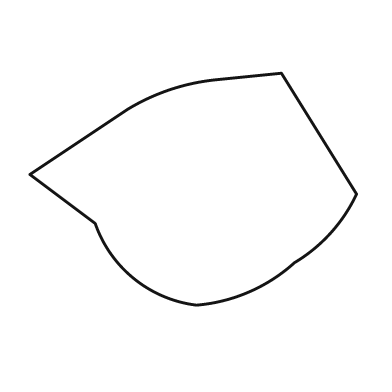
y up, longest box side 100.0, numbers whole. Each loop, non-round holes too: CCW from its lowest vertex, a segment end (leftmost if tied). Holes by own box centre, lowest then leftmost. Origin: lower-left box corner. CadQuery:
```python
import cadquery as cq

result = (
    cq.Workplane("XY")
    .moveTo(51.0, 0.0)
    .threePointArc((67.0, 4.0), (81.0, 13.0))
    .threePointArc((92.0, 22.0), (100.0, 34.0))
    .lineTo(77.0, 71.0)
    .lineTo(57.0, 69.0)
    .threePointArc((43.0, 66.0), (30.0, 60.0))
    .lineTo(0.0, 40.0)
    .lineTo(20.0, 25.0)
    .threePointArc((32.0, 8.0), (51.0, 0.0))
    .close()
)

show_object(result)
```